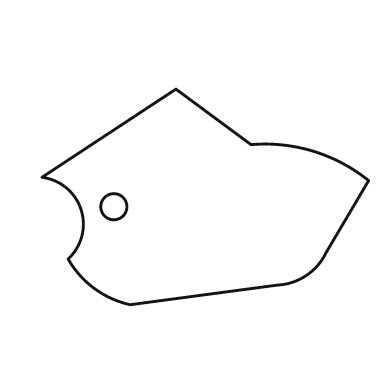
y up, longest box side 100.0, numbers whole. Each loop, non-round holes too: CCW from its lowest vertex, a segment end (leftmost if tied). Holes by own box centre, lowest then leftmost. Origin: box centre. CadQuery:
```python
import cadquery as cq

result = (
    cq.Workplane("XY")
    .moveTo(-23.0, -33.0)
    .lineTo(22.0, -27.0)
    .threePointArc((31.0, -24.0), (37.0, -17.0))
    .lineTo(50.0, 5.0)
    .threePointArc((33.0, 14.0), (14.0, 16.0))
    .lineTo(-9.0, 33.0)
    .lineTo(-50.0, 6.0)
    .threePointArc((-38.0, -4.0), (-42.0, -19.0))
    .threePointArc((-34.0, -28.0), (-23.0, -33.0))
    .close()
    .moveTo(-28.0, -3.0)
    .circle(4.0)
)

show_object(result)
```